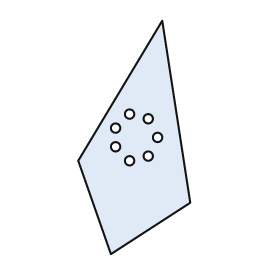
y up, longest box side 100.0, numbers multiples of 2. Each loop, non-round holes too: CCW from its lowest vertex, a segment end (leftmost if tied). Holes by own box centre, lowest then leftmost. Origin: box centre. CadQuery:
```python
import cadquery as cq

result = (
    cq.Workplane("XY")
    .moveTo(-10.0, -50.0)
    .lineTo(24.0, -28.0)
    .lineTo(12.0, 50.0)
    .lineTo(-24.0, -10.0)
    .close()
    .moveTo(-2.0, -10.0)
    .circle(2.0)
    .moveTo(6.0, -8.0)
    .circle(2.0)
    .moveTo(-8.0, -4.0)
    .circle(2.0)
    .moveTo(10.0, 0.0)
    .circle(2.0)
    .moveTo(-8.0, 4.0)
    .circle(2.0)
    .moveTo(6.0, 8.0)
    .circle(2.0)
    .moveTo(-2.0, 10.0)
    .circle(2.0)
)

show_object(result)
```